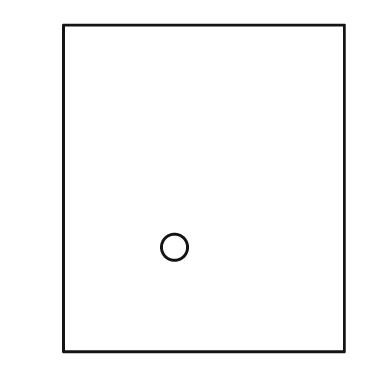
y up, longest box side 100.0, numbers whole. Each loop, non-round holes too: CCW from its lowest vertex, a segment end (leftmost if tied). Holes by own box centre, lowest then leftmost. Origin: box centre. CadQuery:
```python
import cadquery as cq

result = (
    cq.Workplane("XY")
    .moveTo(-43.0, -50.0)
    .lineTo(43.0, -50.0)
    .lineTo(43.0, 50.0)
    .lineTo(-43.0, 50.0)
    .close()
    .moveTo(-9.0, -18.0)
    .circle(4.0)
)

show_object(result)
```